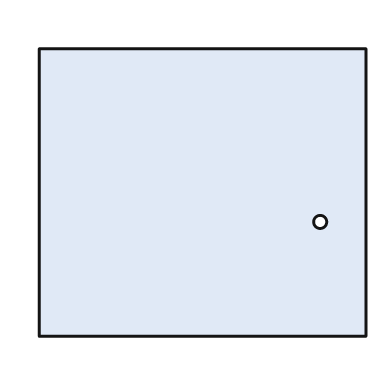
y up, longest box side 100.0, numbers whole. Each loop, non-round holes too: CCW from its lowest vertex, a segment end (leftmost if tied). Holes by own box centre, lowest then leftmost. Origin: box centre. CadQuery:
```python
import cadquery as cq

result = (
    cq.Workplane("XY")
    .moveTo(-50.0, -44.0)
    .lineTo(50.0, -44.0)
    .lineTo(50.0, 44.0)
    .lineTo(-50.0, 44.0)
    .close()
    .moveTo(36.0, -9.0)
    .circle(2.0)
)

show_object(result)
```